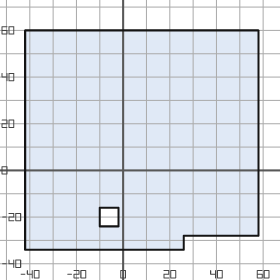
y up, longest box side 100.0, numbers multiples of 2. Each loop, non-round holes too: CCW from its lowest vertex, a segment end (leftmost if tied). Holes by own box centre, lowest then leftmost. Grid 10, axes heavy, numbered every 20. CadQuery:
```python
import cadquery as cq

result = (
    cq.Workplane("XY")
    .moveTo(-42.0, -34.0)
    .lineTo(26.0, -34.0)
    .lineTo(26.0, -28.0)
    .lineTo(58.0, -28.0)
    .lineTo(58.0, 60.0)
    .lineTo(-42.0, 60.0)
    .close()
    .moveTo(-10.0, -24.0)
    .lineTo(-2.0, -24.0)
    .lineTo(-2.0, -16.0)
    .lineTo(-10.0, -16.0)
    .close()
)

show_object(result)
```